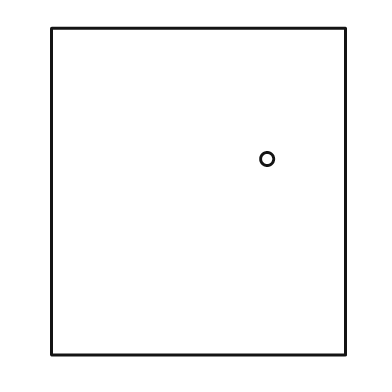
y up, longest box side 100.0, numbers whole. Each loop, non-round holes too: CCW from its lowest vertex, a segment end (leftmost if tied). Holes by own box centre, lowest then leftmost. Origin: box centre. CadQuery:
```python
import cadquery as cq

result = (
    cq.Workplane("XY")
    .moveTo(-45.0, -50.0)
    .lineTo(45.0, -50.0)
    .lineTo(45.0, 50.0)
    .lineTo(-45.0, 50.0)
    .close()
    .moveTo(21.0, 10.0)
    .circle(2.0)
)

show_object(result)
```